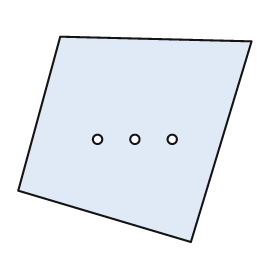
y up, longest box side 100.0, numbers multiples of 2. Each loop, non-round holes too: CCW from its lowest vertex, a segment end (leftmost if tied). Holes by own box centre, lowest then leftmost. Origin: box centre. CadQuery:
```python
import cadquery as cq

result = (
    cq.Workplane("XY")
    .moveTo(24.0, -44.0)
    .lineTo(50.0, 42.0)
    .lineTo(-32.0, 44.0)
    .lineTo(-50.0, -22.0)
    .close()
    .moveTo(-16.0, 0.0)
    .circle(2.0)
    .moveTo(0.0, 0.0)
    .circle(2.0)
    .moveTo(16.0, 0.0)
    .circle(2.0)
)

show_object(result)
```